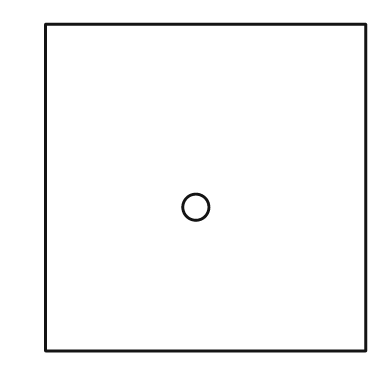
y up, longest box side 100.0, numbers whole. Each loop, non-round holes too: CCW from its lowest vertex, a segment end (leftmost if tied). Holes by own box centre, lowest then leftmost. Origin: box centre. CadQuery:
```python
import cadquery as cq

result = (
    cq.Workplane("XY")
    .moveTo(-49.0, -50.0)
    .lineTo(49.0, -50.0)
    .lineTo(49.0, 50.0)
    .lineTo(-49.0, 50.0)
    .close()
    .moveTo(-3.0, -6.0)
    .circle(4.0)
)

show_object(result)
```